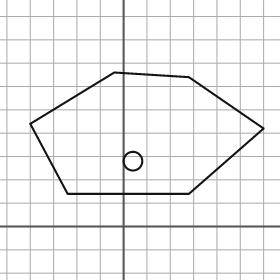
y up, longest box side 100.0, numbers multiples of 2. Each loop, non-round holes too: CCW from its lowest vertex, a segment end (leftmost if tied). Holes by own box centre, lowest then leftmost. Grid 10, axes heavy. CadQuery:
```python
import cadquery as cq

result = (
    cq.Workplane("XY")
    .moveTo(-24.0, 14.0)
    .lineTo(28.0, 14.0)
    .lineTo(60.0, 42.0)
    .lineTo(28.0, 64.0)
    .lineTo(-4.0, 66.0)
    .lineTo(-40.0, 44.0)
    .close()
    .moveTo(4.0, 28.0)
    .circle(4.0)
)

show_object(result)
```